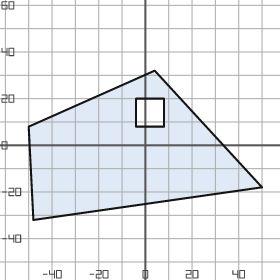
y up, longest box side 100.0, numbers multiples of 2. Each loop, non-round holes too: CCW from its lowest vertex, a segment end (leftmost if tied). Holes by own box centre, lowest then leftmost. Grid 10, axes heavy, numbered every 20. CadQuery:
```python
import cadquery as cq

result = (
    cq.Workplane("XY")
    .moveTo(-48.0, -32.0)
    .lineTo(50.0, -18.0)
    .lineTo(4.0, 32.0)
    .lineTo(-50.0, 8.0)
    .close()
    .moveTo(-4.0, 8.0)
    .lineTo(8.0, 8.0)
    .lineTo(8.0, 20.0)
    .lineTo(-4.0, 20.0)
    .close()
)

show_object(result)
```